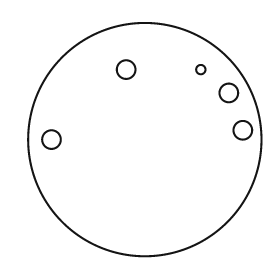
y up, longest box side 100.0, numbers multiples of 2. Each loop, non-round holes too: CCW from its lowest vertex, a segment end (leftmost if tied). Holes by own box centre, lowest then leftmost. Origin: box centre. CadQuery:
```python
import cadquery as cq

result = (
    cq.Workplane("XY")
    .moveTo(0.0, 0.0)
    .circle(50.0)
    .moveTo(-40.0, 0.0)
    .circle(4.0)
    .moveTo(42.0, 4.0)
    .circle(4.0)
    .moveTo(36.0, 20.0)
    .circle(4.0)
    .moveTo(-8.0, 30.0)
    .circle(4.0)
    .moveTo(24.0, 30.0)
    .circle(2.0)
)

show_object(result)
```